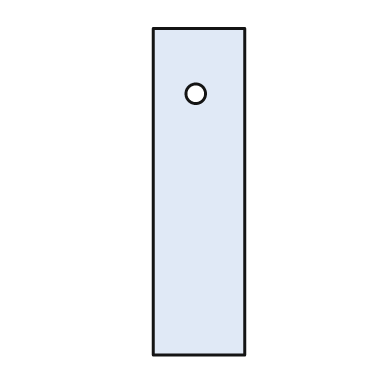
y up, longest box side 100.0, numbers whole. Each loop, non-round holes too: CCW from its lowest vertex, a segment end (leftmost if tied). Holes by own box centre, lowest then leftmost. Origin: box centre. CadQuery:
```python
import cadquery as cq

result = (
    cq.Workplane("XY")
    .moveTo(-14.0, -50.0)
    .lineTo(14.0, -50.0)
    .lineTo(14.0, 50.0)
    .lineTo(-14.0, 50.0)
    .close()
    .moveTo(-1.0, 30.0)
    .circle(3.0)
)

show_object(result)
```